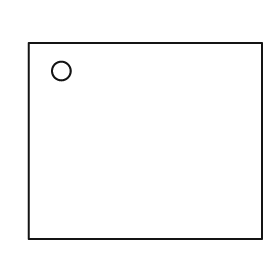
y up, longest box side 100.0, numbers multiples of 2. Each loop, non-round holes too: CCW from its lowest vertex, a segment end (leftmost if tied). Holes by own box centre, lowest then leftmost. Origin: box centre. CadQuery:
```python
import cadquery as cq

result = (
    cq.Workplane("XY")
    .moveTo(-50.0, -42.0)
    .lineTo(50.0, -42.0)
    .lineTo(50.0, 42.0)
    .lineTo(-50.0, 42.0)
    .close()
    .moveTo(-36.0, 30.0)
    .circle(4.0)
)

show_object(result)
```